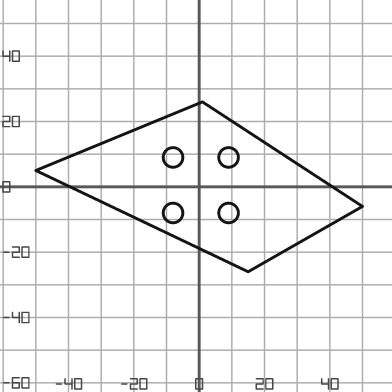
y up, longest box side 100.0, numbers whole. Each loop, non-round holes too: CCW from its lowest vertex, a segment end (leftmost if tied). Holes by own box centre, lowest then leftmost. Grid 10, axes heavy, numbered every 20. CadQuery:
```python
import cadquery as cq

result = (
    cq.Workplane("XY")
    .moveTo(15.0, -26.0)
    .lineTo(50.0, -6.0)
    .lineTo(1.0, 26.0)
    .lineTo(-50.0, 5.0)
    .close()
    .moveTo(-8.0, -8.0)
    .circle(3.0)
    .moveTo(9.0, -8.0)
    .circle(3.0)
    .moveTo(-8.0, 9.0)
    .circle(3.0)
    .moveTo(9.0, 9.0)
    .circle(3.0)
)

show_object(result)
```